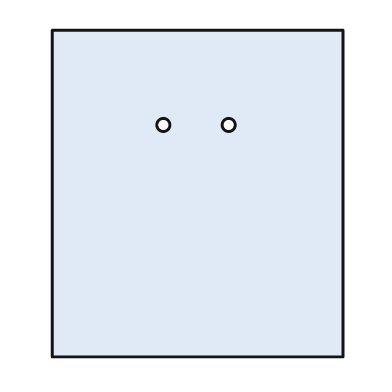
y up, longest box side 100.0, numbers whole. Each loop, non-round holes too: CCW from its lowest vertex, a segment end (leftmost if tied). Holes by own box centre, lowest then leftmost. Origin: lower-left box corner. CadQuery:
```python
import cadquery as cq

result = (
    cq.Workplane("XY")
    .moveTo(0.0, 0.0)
    .lineTo(89.0, 0.0)
    .lineTo(89.0, 100.0)
    .lineTo(0.0, 100.0)
    .close()
    .moveTo(34.0, 71.0)
    .circle(2.0)
    .moveTo(54.0, 71.0)
    .circle(2.0)
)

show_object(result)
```